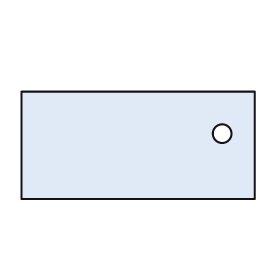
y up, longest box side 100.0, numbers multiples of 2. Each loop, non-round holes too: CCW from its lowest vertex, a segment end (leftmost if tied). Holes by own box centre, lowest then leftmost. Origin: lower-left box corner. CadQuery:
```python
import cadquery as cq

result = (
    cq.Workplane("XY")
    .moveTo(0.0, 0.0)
    .lineTo(100.0, 0.0)
    .lineTo(100.0, 46.0)
    .lineTo(0.0, 46.0)
    .close()
    .moveTo(86.0, 28.0)
    .circle(4.0)
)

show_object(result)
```